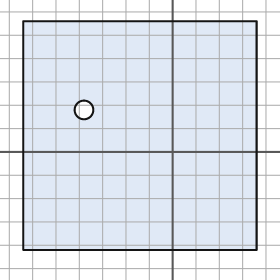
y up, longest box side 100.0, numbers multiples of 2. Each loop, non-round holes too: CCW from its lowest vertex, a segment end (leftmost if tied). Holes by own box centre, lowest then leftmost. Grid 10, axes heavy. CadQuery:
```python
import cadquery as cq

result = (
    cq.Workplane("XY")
    .moveTo(-64.0, -42.0)
    .lineTo(36.0, -42.0)
    .lineTo(36.0, 56.0)
    .lineTo(-64.0, 56.0)
    .close()
    .moveTo(-38.0, 18.0)
    .circle(4.0)
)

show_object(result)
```